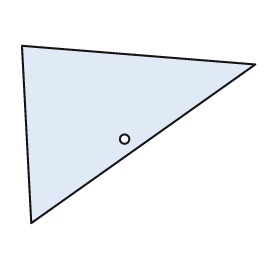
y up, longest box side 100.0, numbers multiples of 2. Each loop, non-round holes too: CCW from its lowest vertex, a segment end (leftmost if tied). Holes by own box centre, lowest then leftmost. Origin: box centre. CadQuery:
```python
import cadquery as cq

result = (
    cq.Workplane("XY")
    .moveTo(-46.0, -38.0)
    .lineTo(50.0, 30.0)
    .lineTo(-50.0, 38.0)
    .close()
    .moveTo(-6.0, -2.0)
    .circle(2.0)
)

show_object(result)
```